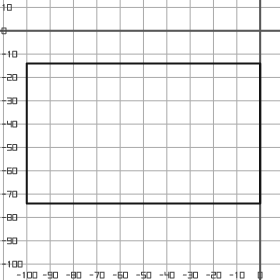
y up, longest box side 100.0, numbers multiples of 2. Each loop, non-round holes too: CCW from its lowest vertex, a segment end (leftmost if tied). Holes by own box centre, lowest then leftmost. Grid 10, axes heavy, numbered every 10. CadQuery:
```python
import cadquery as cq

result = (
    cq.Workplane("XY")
    .moveTo(-100.0, -74.0)
    .lineTo(0.0, -74.0)
    .lineTo(0.0, -14.0)
    .lineTo(-100.0, -14.0)
    .close()
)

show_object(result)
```